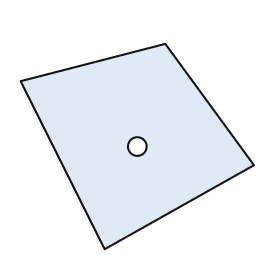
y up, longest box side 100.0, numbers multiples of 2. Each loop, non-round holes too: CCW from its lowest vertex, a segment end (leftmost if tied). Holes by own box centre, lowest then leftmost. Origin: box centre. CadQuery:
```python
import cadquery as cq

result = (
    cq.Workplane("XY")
    .moveTo(-14.0, -44.0)
    .lineTo(50.0, -8.0)
    .lineTo(12.0, 44.0)
    .lineTo(-50.0, 28.0)
    .close()
    .moveTo(0.0, 0.0)
    .circle(4.0)
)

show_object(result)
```